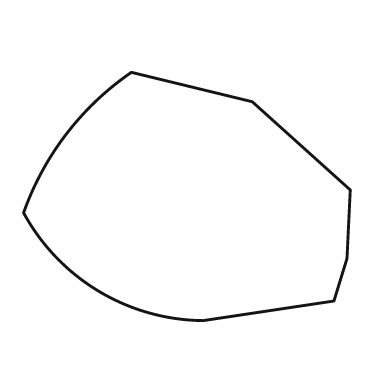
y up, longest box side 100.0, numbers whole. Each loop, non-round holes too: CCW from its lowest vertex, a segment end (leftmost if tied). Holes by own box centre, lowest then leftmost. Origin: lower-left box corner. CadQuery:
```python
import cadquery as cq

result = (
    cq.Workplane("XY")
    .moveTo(55.0, 0.0)
    .lineTo(95.0, 6.0)
    .lineTo(99.0, 19.0)
    .lineTo(100.0, 40.0)
    .lineTo(70.0, 67.0)
    .lineTo(33.0, 76.0)
    .threePointArc((13.0, 57.0), (0.0, 33.0))
    .threePointArc((23.0, 9.0), (55.0, 0.0))
    .close()
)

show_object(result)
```